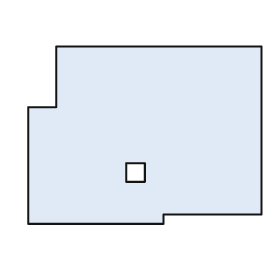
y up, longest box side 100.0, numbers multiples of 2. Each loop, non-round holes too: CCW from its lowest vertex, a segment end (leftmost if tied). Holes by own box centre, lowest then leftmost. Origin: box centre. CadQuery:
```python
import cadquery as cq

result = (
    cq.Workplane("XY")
    .moveTo(-50.0, -38.0)
    .lineTo(8.0, -38.0)
    .lineTo(8.0, -34.0)
    .lineTo(50.0, -34.0)
    .lineTo(50.0, 38.0)
    .lineTo(-38.0, 38.0)
    .lineTo(-38.0, 12.0)
    .lineTo(-50.0, 12.0)
    .close()
    .moveTo(-8.0, -20.0)
    .lineTo(0.0, -20.0)
    .lineTo(0.0, -12.0)
    .lineTo(-8.0, -12.0)
    .close()
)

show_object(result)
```